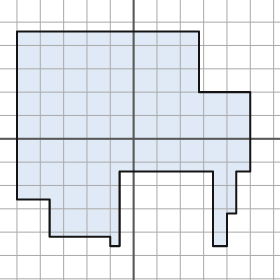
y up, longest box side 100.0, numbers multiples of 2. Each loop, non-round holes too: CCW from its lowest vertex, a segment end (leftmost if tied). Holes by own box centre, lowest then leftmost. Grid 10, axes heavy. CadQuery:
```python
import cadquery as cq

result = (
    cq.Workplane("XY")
    .moveTo(-10.0, -46.0)
    .lineTo(-6.0, -46.0)
    .lineTo(-6.0, -14.0)
    .lineTo(34.0, -14.0)
    .lineTo(34.0, -46.0)
    .lineTo(40.0, -46.0)
    .lineTo(40.0, -32.0)
    .lineTo(44.0, -32.0)
    .lineTo(44.0, -14.0)
    .lineTo(50.0, -14.0)
    .lineTo(50.0, 20.0)
    .lineTo(28.0, 20.0)
    .lineTo(28.0, 46.0)
    .lineTo(-50.0, 46.0)
    .lineTo(-50.0, -26.0)
    .lineTo(-36.0, -26.0)
    .lineTo(-36.0, -42.0)
    .lineTo(-10.0, -42.0)
    .close()
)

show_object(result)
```